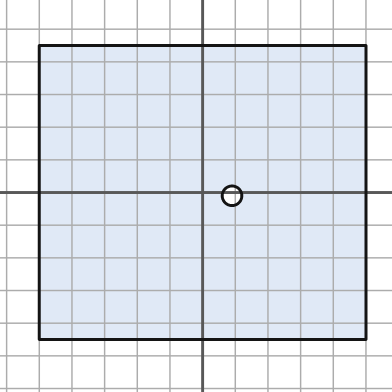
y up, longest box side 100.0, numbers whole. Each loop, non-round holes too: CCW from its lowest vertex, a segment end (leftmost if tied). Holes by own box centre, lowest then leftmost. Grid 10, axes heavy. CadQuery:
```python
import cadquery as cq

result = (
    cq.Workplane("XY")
    .moveTo(-50.0, -45.0)
    .lineTo(50.0, -45.0)
    .lineTo(50.0, 45.0)
    .lineTo(-50.0, 45.0)
    .close()
    .moveTo(9.0, -1.0)
    .circle(3.0)
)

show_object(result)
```